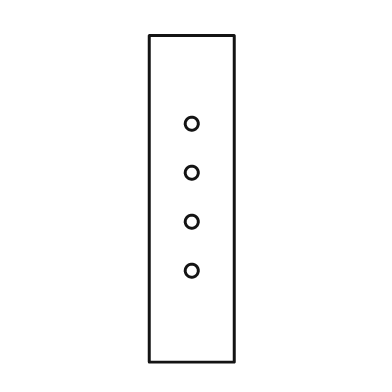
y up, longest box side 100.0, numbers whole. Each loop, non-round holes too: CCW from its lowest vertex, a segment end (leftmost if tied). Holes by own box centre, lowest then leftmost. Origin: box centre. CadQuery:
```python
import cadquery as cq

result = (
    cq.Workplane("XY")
    .moveTo(-13.0, -50.0)
    .lineTo(13.0, -50.0)
    .lineTo(13.0, 50.0)
    .lineTo(-13.0, 50.0)
    .close()
    .moveTo(0.0, -22.0)
    .circle(2.0)
    .moveTo(0.0, -7.0)
    .circle(2.0)
    .moveTo(0.0, 8.0)
    .circle(2.0)
    .moveTo(0.0, 23.0)
    .circle(2.0)
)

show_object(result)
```